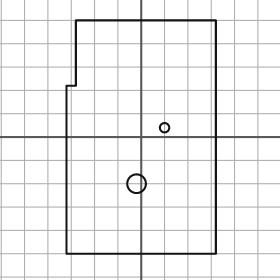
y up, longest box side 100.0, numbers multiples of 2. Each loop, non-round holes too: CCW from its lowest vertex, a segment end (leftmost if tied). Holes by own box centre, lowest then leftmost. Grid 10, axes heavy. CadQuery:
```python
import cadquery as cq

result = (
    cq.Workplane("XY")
    .moveTo(-32.0, -50.0)
    .lineTo(32.0, -50.0)
    .lineTo(32.0, 50.0)
    .lineTo(-28.0, 50.0)
    .lineTo(-28.0, 22.0)
    .lineTo(-32.0, 22.0)
    .close()
    .moveTo(-2.0, -20.0)
    .circle(4.0)
    .moveTo(10.0, 4.0)
    .circle(2.0)
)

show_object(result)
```